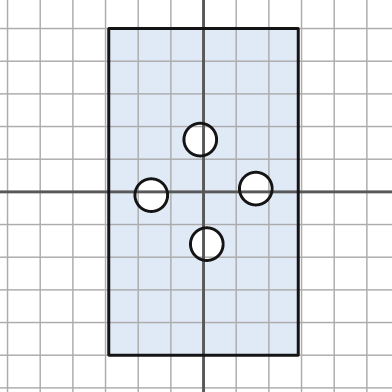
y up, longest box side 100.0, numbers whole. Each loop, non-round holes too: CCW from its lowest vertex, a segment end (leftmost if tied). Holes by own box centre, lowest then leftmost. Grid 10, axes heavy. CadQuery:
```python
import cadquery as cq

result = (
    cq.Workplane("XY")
    .moveTo(-29.0, -50.0)
    .lineTo(29.0, -50.0)
    .lineTo(29.0, 50.0)
    .lineTo(-29.0, 50.0)
    .close()
    .moveTo(1.0, -16.0)
    .circle(5.0)
    .moveTo(-16.0, -1.0)
    .circle(5.0)
    .moveTo(16.0, 1.0)
    .circle(5.0)
    .moveTo(-1.0, 16.0)
    .circle(5.0)
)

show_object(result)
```